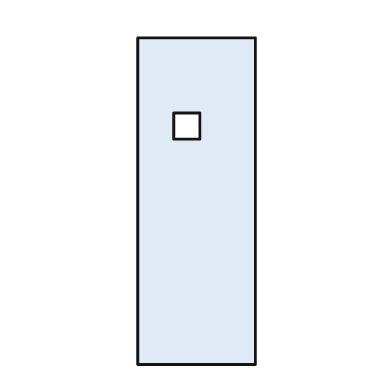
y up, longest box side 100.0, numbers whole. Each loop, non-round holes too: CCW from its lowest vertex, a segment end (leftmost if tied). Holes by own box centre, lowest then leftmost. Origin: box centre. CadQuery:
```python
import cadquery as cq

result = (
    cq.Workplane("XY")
    .moveTo(-18.0, -50.0)
    .lineTo(18.0, -50.0)
    .lineTo(18.0, 50.0)
    .lineTo(-18.0, 50.0)
    .close()
    .moveTo(-7.0, 19.0)
    .lineTo(1.0, 19.0)
    .lineTo(1.0, 27.0)
    .lineTo(-7.0, 27.0)
    .close()
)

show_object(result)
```